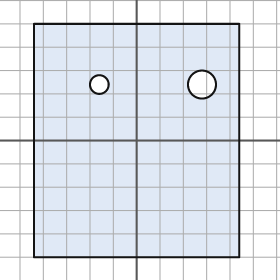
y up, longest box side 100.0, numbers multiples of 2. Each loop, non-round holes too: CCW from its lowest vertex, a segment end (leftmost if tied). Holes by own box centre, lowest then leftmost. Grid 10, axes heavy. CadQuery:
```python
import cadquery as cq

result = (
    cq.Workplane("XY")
    .moveTo(-44.0, -50.0)
    .lineTo(44.0, -50.0)
    .lineTo(44.0, 50.0)
    .lineTo(-44.0, 50.0)
    .close()
    .moveTo(-16.0, 24.0)
    .circle(4.0)
    .moveTo(28.0, 24.0)
    .circle(6.0)
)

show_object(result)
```